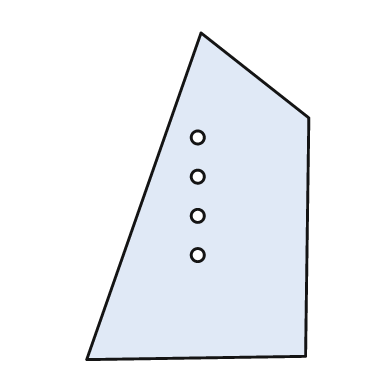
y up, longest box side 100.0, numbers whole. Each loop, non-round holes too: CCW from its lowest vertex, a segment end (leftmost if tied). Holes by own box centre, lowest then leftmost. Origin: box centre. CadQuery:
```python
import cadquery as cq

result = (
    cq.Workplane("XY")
    .moveTo(-34.0, -50.0)
    .lineTo(33.0, -49.0)
    .lineTo(34.0, 24.0)
    .lineTo(1.0, 50.0)
    .close()
    .moveTo(0.0, -18.0)
    .circle(2.0)
    .moveTo(0.0, -6.0)
    .circle(2.0)
    .moveTo(0.0, 6.0)
    .circle(2.0)
    .moveTo(0.0, 18.0)
    .circle(2.0)
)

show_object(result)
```